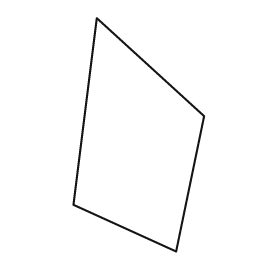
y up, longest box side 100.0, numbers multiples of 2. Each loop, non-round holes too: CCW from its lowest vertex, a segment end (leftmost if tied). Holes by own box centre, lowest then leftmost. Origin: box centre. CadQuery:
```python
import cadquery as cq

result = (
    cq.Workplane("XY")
    .moveTo(16.0, -50.0)
    .lineTo(28.0, 8.0)
    .lineTo(-18.0, 50.0)
    .lineTo(-28.0, -30.0)
    .close()
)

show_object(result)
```